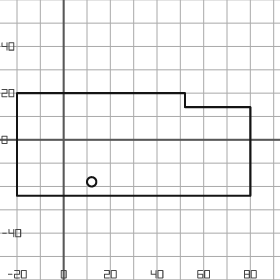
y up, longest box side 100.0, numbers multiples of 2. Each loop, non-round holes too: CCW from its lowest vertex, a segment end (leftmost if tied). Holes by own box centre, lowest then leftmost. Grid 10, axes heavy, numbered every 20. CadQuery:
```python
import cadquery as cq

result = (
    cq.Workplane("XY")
    .moveTo(-20.0, -24.0)
    .lineTo(80.0, -24.0)
    .lineTo(80.0, 14.0)
    .lineTo(52.0, 14.0)
    .lineTo(52.0, 20.0)
    .lineTo(-20.0, 20.0)
    .close()
    .moveTo(12.0, -18.0)
    .circle(2.0)
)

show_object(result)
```